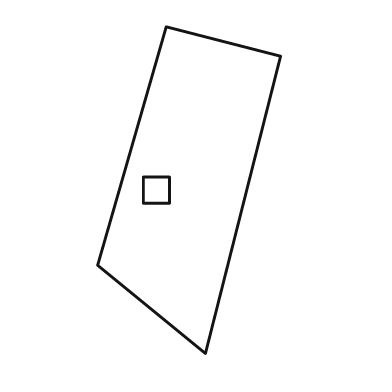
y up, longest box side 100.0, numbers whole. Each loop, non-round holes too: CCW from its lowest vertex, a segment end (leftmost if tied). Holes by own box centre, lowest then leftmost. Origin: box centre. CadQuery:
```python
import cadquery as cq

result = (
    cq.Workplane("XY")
    .moveTo(5.0, -50.0)
    .lineTo(28.0, 41.0)
    .lineTo(-7.0, 50.0)
    .lineTo(-28.0, -23.0)
    .close()
    .moveTo(-14.0, -4.0)
    .lineTo(-6.0, -4.0)
    .lineTo(-6.0, 4.0)
    .lineTo(-14.0, 4.0)
    .close()
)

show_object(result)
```